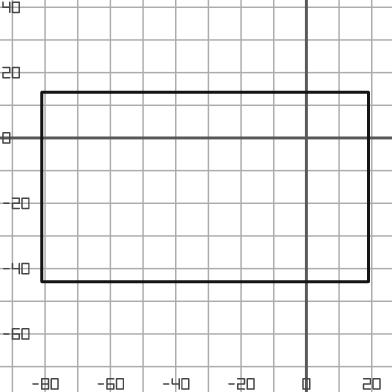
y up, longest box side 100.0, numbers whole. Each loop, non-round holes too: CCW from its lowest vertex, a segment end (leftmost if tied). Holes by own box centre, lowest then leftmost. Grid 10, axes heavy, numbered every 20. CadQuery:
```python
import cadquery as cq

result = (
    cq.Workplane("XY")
    .moveTo(-81.0, -44.0)
    .lineTo(19.0, -44.0)
    .lineTo(19.0, 14.0)
    .lineTo(-81.0, 14.0)
    .close()
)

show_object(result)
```